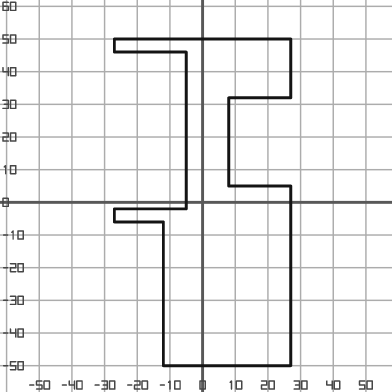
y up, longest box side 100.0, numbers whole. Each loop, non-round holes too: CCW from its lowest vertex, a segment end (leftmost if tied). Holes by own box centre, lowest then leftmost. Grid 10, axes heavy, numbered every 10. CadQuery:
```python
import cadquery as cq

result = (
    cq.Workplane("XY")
    .moveTo(-12.0, -50.0)
    .lineTo(27.0, -50.0)
    .lineTo(27.0, 5.0)
    .lineTo(8.0, 5.0)
    .lineTo(8.0, 32.0)
    .lineTo(27.0, 32.0)
    .lineTo(27.0, 50.0)
    .lineTo(-27.0, 50.0)
    .lineTo(-27.0, 46.0)
    .lineTo(-5.0, 46.0)
    .lineTo(-5.0, -2.0)
    .lineTo(-27.0, -2.0)
    .lineTo(-27.0, -6.0)
    .lineTo(-12.0, -6.0)
    .close()
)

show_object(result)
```